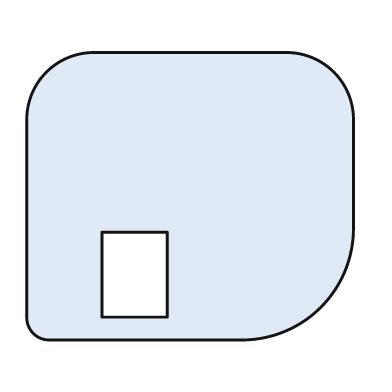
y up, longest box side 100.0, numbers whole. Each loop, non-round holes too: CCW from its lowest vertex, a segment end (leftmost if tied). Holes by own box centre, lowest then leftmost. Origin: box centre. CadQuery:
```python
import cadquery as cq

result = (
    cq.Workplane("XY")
    .moveTo(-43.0, -44.0)
    .lineTo(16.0, -44.0)
    .threePointArc((40.0, -34.0), (50.0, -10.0))
    .lineTo(50.0, 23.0)
    .threePointArc((44.0, 38.0), (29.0, 44.0))
    .lineTo(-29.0, 44.0)
    .threePointArc((-44.0, 38.0), (-50.0, 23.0))
    .lineTo(-50.0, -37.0)
    .threePointArc((-48.0, -42.0), (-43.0, -44.0))
    .close()
    .moveTo(-27.0, -37.0)
    .lineTo(-7.0, -37.0)
    .lineTo(-7.0, -11.0)
    .lineTo(-27.0, -11.0)
    .close()
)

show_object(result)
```